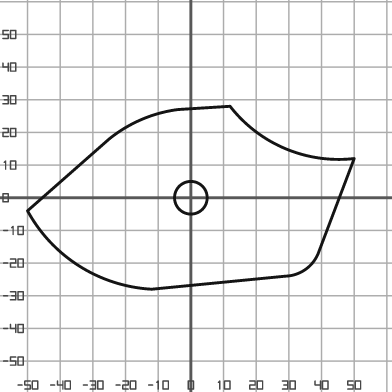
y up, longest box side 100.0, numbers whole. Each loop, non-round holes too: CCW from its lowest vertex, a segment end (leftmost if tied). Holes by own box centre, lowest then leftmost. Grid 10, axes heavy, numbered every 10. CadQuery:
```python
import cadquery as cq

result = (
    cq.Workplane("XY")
    .moveTo(-12.0, -28.0)
    .lineTo(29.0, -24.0)
    .threePointArc((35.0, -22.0), (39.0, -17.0))
    .lineTo(50.0, 12.0)
    .threePointArc((29.0, 15.0), (12.0, 28.0))
    .lineTo(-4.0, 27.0)
    .threePointArc((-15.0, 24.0), (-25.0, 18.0))
    .lineTo(-50.0, -4.0)
    .threePointArc((-34.0, -21.0), (-12.0, -28.0))
    .close()
    .moveTo(0.0, 0.0)
    .circle(5.0)
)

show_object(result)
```